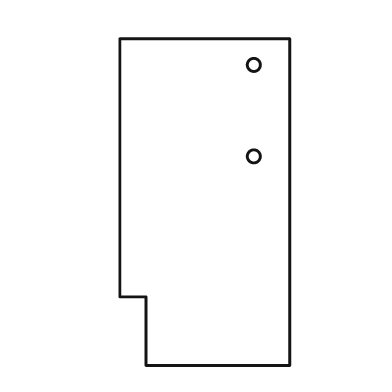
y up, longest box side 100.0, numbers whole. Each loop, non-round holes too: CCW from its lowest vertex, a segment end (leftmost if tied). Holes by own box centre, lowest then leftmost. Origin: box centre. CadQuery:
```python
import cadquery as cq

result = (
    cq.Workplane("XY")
    .moveTo(-18.0, -50.0)
    .lineTo(26.0, -50.0)
    .lineTo(26.0, 50.0)
    .lineTo(-26.0, 50.0)
    .lineTo(-26.0, -29.0)
    .lineTo(-18.0, -29.0)
    .close()
    .moveTo(15.0, 14.0)
    .circle(2.0)
    .moveTo(15.0, 42.0)
    .circle(2.0)
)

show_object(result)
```